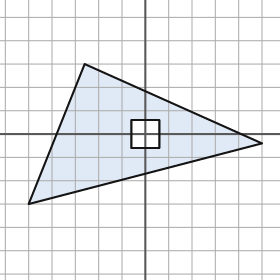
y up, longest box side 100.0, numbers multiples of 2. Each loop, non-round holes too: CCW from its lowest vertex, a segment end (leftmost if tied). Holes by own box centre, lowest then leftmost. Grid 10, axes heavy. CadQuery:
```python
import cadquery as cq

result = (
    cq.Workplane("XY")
    .moveTo(-50.0, -30.0)
    .lineTo(50.0, -4.0)
    .lineTo(-26.0, 30.0)
    .close()
    .moveTo(-6.0, -6.0)
    .lineTo(6.0, -6.0)
    .lineTo(6.0, 6.0)
    .lineTo(-6.0, 6.0)
    .close()
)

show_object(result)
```